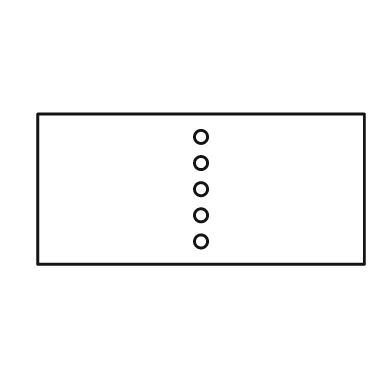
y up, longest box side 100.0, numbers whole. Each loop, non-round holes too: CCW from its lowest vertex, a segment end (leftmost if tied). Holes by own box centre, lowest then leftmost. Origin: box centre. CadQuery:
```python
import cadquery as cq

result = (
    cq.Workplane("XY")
    .moveTo(-50.0, -23.0)
    .lineTo(50.0, -23.0)
    .lineTo(50.0, 23.0)
    .lineTo(-50.0, 23.0)
    .close()
    .moveTo(0.0, -16.0)
    .circle(2.0)
    .moveTo(0.0, -8.0)
    .circle(2.0)
    .moveTo(0.0, 0.0)
    .circle(2.0)
    .moveTo(0.0, 8.0)
    .circle(2.0)
    .moveTo(0.0, 16.0)
    .circle(2.0)
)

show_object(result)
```